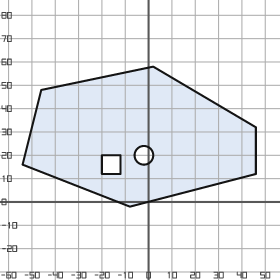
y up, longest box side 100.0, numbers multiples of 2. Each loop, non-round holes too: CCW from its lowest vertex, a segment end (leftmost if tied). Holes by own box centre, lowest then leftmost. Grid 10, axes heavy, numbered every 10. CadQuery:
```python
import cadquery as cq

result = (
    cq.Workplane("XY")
    .moveTo(-8.0, -2.0)
    .lineTo(46.0, 12.0)
    .lineTo(46.0, 32.0)
    .lineTo(2.0, 58.0)
    .lineTo(-46.0, 48.0)
    .lineTo(-54.0, 16.0)
    .close()
    .moveTo(-20.0, 12.0)
    .lineTo(-12.0, 12.0)
    .lineTo(-12.0, 20.0)
    .lineTo(-20.0, 20.0)
    .close()
    .moveTo(-2.0, 20.0)
    .circle(4.0)
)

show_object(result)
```